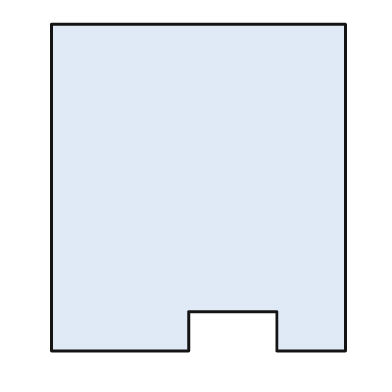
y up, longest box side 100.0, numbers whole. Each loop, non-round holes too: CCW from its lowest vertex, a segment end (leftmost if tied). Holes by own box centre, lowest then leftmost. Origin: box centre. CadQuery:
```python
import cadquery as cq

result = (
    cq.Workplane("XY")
    .moveTo(-45.0, -50.0)
    .lineTo(-3.0, -50.0)
    .lineTo(-3.0, -38.0)
    .lineTo(24.0, -38.0)
    .lineTo(24.0, -50.0)
    .lineTo(45.0, -50.0)
    .lineTo(45.0, 50.0)
    .lineTo(-45.0, 50.0)
    .close()
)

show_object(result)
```